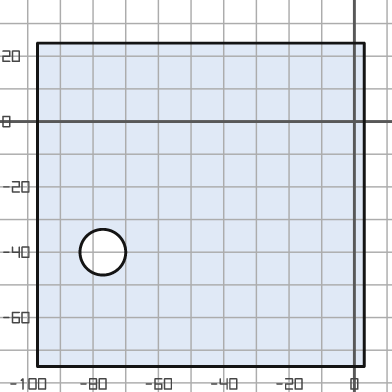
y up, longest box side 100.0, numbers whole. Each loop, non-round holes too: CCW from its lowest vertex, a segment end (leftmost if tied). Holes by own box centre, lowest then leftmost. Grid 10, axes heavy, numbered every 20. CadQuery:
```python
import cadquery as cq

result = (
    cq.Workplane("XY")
    .moveTo(-97.0, -75.0)
    .lineTo(3.0, -75.0)
    .lineTo(3.0, 24.0)
    .lineTo(-97.0, 24.0)
    .close()
    .moveTo(-77.0, -40.0)
    .circle(7.0)
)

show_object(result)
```